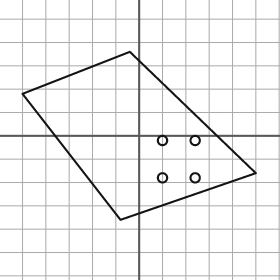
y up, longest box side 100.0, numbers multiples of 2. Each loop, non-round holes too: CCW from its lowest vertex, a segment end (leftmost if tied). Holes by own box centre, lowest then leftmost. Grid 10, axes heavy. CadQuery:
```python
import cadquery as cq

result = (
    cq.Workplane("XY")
    .moveTo(-8.0, -36.0)
    .lineTo(50.0, -16.0)
    .lineTo(-4.0, 36.0)
    .lineTo(-50.0, 18.0)
    .close()
    .moveTo(10.0, -18.0)
    .circle(2.0)
    .moveTo(24.0, -18.0)
    .circle(2.0)
    .moveTo(10.0, -2.0)
    .circle(2.0)
    .moveTo(24.0, -2.0)
    .circle(2.0)
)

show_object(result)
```